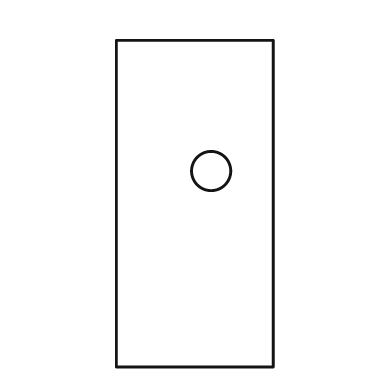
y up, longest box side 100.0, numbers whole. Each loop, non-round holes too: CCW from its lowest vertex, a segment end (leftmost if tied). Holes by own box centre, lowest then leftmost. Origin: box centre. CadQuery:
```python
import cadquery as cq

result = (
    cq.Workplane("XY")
    .moveTo(-24.0, -50.0)
    .lineTo(24.0, -50.0)
    .lineTo(24.0, 50.0)
    .lineTo(-24.0, 50.0)
    .close()
    .moveTo(5.0, 10.0)
    .circle(6.0)
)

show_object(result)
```